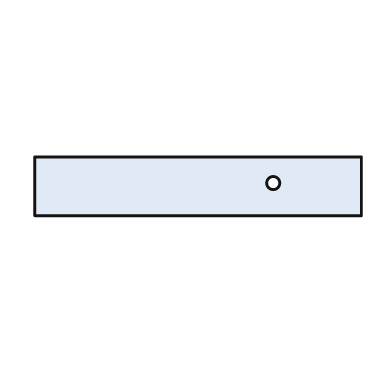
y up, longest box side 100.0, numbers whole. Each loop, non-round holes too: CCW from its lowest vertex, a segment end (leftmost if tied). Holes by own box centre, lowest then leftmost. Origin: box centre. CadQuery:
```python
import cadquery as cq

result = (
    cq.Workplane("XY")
    .moveTo(-50.0, -9.0)
    .lineTo(50.0, -9.0)
    .lineTo(50.0, 9.0)
    .lineTo(-50.0, 9.0)
    .close()
    .moveTo(23.0, 1.0)
    .circle(2.0)
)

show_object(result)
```